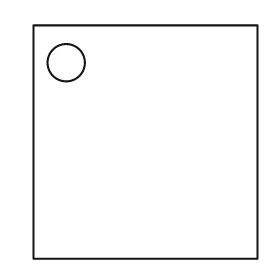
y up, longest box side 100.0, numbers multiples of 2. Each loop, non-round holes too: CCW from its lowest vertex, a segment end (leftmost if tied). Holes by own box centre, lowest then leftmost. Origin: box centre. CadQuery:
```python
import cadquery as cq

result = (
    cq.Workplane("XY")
    .moveTo(-48.0, -50.0)
    .lineTo(48.0, -50.0)
    .lineTo(48.0, 50.0)
    .lineTo(-48.0, 50.0)
    .close()
    .moveTo(-34.0, 34.0)
    .circle(8.0)
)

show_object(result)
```